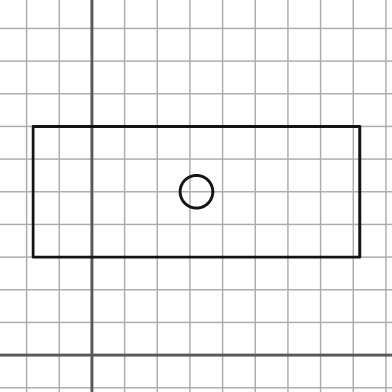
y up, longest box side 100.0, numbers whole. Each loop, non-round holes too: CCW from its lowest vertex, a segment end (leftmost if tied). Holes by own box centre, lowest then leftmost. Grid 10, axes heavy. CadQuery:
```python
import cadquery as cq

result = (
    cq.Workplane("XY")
    .moveTo(-18.0, 30.0)
    .lineTo(82.0, 30.0)
    .lineTo(82.0, 70.0)
    .lineTo(-18.0, 70.0)
    .close()
    .moveTo(32.0, 50.0)
    .circle(5.0)
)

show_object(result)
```